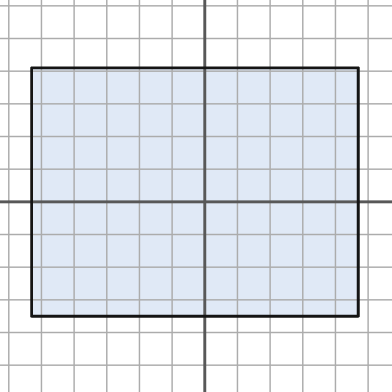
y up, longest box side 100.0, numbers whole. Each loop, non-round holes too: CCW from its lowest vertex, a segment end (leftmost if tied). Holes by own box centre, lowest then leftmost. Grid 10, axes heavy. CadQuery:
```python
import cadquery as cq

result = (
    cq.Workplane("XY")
    .moveTo(-53.0, -35.0)
    .lineTo(47.0, -35.0)
    .lineTo(47.0, 41.0)
    .lineTo(-53.0, 41.0)
    .close()
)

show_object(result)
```